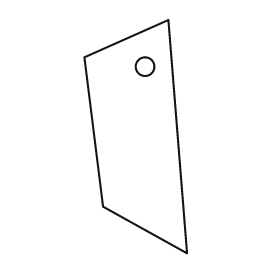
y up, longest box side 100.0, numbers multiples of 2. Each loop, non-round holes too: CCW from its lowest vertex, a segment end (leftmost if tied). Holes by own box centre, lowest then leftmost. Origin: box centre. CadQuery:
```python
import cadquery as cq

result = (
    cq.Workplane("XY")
    .moveTo(22.0, -50.0)
    .lineTo(14.0, 50.0)
    .lineTo(-22.0, 34.0)
    .lineTo(-14.0, -30.0)
    .close()
    .moveTo(4.0, 30.0)
    .circle(4.0)
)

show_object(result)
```